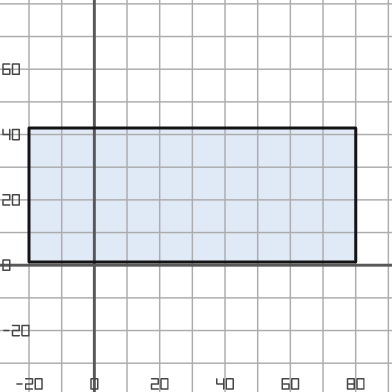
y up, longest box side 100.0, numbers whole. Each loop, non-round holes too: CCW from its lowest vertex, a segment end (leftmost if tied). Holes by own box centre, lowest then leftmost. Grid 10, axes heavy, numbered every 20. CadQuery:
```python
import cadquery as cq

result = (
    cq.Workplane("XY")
    .moveTo(-20.0, 1.0)
    .lineTo(80.0, 1.0)
    .lineTo(80.0, 42.0)
    .lineTo(-20.0, 42.0)
    .close()
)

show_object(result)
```